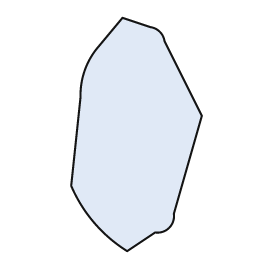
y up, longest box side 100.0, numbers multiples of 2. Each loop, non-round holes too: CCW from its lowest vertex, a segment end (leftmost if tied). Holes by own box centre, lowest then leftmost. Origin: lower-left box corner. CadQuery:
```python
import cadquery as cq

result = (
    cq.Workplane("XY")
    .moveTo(24.0, 0.0)
    .lineTo(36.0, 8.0)
    .threePointArc((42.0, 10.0), (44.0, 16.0))
    .lineTo(56.0, 58.0)
    .lineTo(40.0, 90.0)
    .threePointArc((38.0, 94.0), (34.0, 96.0))
    .lineTo(22.0, 100.0)
    .lineTo(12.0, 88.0)
    .threePointArc((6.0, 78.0), (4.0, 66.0))
    .lineTo(0.0, 28.0)
    .threePointArc((10.0, 12.0), (24.0, 0.0))
    .close()
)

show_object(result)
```